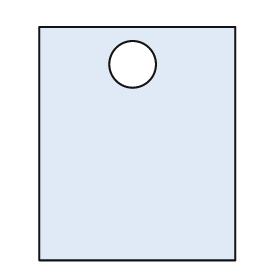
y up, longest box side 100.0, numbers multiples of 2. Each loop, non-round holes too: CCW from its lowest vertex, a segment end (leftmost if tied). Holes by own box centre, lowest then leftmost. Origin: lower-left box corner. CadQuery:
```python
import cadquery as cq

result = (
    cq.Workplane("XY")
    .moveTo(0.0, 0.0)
    .lineTo(84.0, 0.0)
    .lineTo(84.0, 100.0)
    .lineTo(0.0, 100.0)
    .close()
    .moveTo(40.0, 84.0)
    .circle(10.0)
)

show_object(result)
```